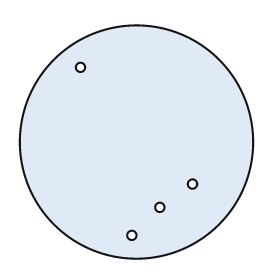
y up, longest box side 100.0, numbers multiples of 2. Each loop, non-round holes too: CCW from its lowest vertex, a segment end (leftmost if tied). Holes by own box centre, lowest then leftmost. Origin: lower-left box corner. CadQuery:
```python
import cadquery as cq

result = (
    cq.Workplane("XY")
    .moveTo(50.0, 50.0)
    .circle(50.0)
    .moveTo(48.0, 10.0)
    .circle(2.0)
    .moveTo(60.0, 22.0)
    .circle(2.0)
    .moveTo(74.0, 32.0)
    .circle(2.0)
    .moveTo(26.0, 82.0)
    .circle(2.0)
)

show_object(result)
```